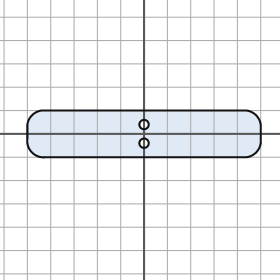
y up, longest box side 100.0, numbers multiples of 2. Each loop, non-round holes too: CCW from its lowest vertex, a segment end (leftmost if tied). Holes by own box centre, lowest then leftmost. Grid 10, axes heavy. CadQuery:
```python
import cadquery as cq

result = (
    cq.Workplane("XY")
    .moveTo(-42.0, -10.0)
    .lineTo(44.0, -10.0)
    .threePointArc((48.0, -8.0), (50.0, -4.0))
    .lineTo(50.0, 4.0)
    .threePointArc((48.0, 8.0), (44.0, 10.0))
    .lineTo(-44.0, 10.0)
    .threePointArc((-48.0, 8.0), (-50.0, 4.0))
    .lineTo(-50.0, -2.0)
    .threePointArc((-48.0, -8.0), (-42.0, -10.0))
    .close()
    .moveTo(0.0, -4.0)
    .circle(2.0)
    .moveTo(0.0, 4.0)
    .circle(2.0)
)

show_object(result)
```